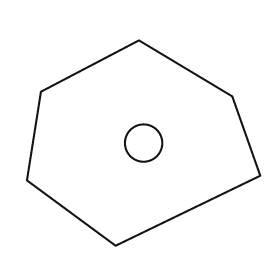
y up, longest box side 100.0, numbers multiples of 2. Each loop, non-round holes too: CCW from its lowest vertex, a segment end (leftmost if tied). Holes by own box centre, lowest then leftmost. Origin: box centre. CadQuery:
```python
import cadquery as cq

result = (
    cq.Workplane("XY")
    .moveTo(-12.0, -44.0)
    .lineTo(50.0, -14.0)
    .lineTo(38.0, 20.0)
    .lineTo(-2.0, 44.0)
    .lineTo(-44.0, 22.0)
    .lineTo(-50.0, -16.0)
    .close()
    .moveTo(0.0, 0.0)
    .circle(8.0)
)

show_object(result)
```